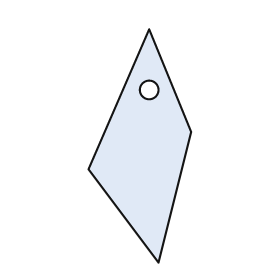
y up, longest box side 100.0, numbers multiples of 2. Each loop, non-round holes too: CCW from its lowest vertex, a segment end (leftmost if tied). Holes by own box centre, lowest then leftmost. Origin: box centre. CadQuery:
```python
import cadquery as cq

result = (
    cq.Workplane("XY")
    .moveTo(8.0, -50.0)
    .lineTo(22.0, 6.0)
    .lineTo(4.0, 50.0)
    .lineTo(-22.0, -10.0)
    .close()
    .moveTo(4.0, 24.0)
    .circle(4.0)
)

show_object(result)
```